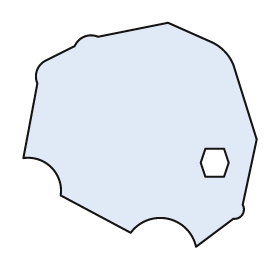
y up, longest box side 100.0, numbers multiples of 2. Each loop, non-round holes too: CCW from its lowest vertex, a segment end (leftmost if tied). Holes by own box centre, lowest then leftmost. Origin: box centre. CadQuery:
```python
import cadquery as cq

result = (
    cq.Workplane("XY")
    .moveTo(24.0, -48.0)
    .lineTo(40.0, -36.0)
    .threePointArc((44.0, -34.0), (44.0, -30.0))
    .lineTo(50.0, -2.0)
    .lineTo(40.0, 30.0)
    .threePointArc((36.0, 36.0), (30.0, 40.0))
    .lineTo(12.0, 48.0)
    .lineTo(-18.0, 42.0)
    .threePointArc((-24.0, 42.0), (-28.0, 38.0))
    .lineTo(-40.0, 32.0)
    .threePointArc((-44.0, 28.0), (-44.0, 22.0))
    .lineTo(-50.0, -10.0)
    .threePointArc((-38.0, -14.0), (-34.0, -26.0))
    .lineTo(-4.0, -42.0)
    .threePointArc((12.0, -36.0), (24.0, -48.0))
    .close()
    .moveTo(28.0, -18.0)
    .lineTo(36.0, -18.0)
    .lineTo(38.0, -12.0)
    .lineTo(36.0, -6.0)
    .lineTo(28.0, -6.0)
    .lineTo(26.0, -12.0)
    .close()
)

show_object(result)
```